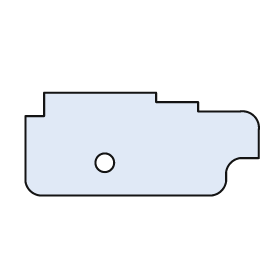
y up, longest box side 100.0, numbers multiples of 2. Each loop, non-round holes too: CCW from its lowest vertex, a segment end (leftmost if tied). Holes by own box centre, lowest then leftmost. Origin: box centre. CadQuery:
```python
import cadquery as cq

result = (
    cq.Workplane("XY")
    .moveTo(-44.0, -22.0)
    .lineTo(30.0, -22.0)
    .threePointArc((34.0, -20.0), (36.0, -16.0))
    .lineTo(36.0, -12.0)
    .threePointArc((38.0, -8.0), (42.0, -6.0))
    .lineTo(50.0, -6.0)
    .lineTo(50.0, 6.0)
    .threePointArc((48.0, 12.0), (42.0, 14.0))
    .lineTo(24.0, 14.0)
    .lineTo(24.0, 18.0)
    .lineTo(6.0, 18.0)
    .lineTo(6.0, 22.0)
    .lineTo(-42.0, 22.0)
    .lineTo(-42.0, 12.0)
    .lineTo(-50.0, 12.0)
    .lineTo(-50.0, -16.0)
    .threePointArc((-48.0, -20.0), (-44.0, -22.0))
    .close()
    .moveTo(-16.0, -8.0)
    .circle(4.0)
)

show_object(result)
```